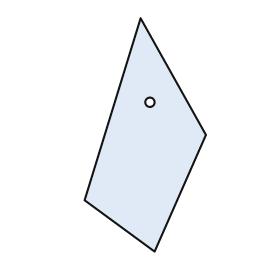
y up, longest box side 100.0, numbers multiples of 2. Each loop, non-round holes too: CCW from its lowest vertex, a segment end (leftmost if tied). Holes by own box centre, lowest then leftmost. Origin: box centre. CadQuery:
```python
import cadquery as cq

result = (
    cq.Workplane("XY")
    .moveTo(4.0, -50.0)
    .lineTo(26.0, 0.0)
    .lineTo(-2.0, 50.0)
    .lineTo(-26.0, -28.0)
    .close()
    .moveTo(2.0, 14.0)
    .circle(2.0)
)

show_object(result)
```